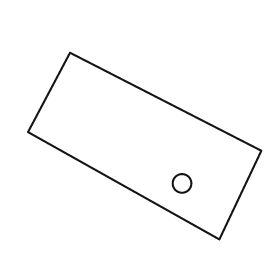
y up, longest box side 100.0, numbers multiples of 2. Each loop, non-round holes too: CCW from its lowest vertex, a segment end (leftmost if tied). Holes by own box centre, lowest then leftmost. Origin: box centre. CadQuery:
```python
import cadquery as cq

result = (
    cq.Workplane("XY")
    .moveTo(32.0, -40.0)
    .lineTo(50.0, -2.0)
    .lineTo(-32.0, 40.0)
    .lineTo(-50.0, 6.0)
    .close()
    .moveTo(16.0, -16.0)
    .circle(4.0)
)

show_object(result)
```